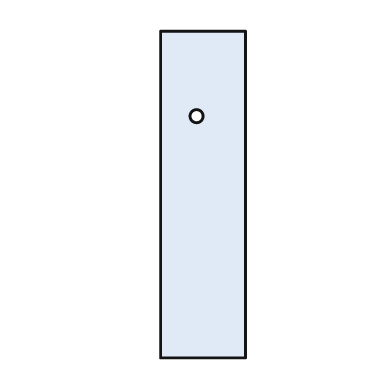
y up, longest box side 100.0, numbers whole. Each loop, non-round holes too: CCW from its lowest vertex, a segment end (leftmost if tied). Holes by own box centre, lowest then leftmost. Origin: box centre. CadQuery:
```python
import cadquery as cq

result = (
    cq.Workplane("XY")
    .moveTo(-13.0, -50.0)
    .lineTo(13.0, -50.0)
    .lineTo(13.0, 50.0)
    .lineTo(-13.0, 50.0)
    .close()
    .moveTo(-2.0, 24.0)
    .circle(2.0)
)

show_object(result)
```